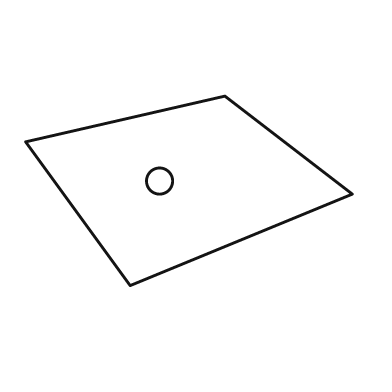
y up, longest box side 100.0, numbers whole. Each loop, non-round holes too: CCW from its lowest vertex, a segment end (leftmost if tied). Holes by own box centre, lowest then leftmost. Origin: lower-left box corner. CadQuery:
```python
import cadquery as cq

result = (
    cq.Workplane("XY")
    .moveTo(32.0, 0.0)
    .lineTo(100.0, 28.0)
    .lineTo(61.0, 58.0)
    .lineTo(0.0, 44.0)
    .close()
    .moveTo(41.0, 32.0)
    .circle(4.0)
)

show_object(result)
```